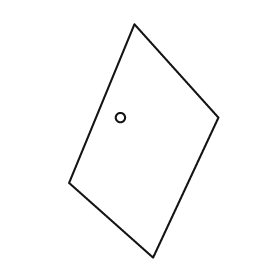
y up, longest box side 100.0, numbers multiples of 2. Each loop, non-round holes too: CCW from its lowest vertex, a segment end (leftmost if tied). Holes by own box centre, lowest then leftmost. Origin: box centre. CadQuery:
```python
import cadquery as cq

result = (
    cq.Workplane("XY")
    .moveTo(4.0, -50.0)
    .lineTo(32.0, 10.0)
    .lineTo(-4.0, 50.0)
    .lineTo(-32.0, -18.0)
    .close()
    .moveTo(-10.0, 10.0)
    .circle(2.0)
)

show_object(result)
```